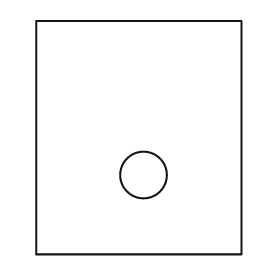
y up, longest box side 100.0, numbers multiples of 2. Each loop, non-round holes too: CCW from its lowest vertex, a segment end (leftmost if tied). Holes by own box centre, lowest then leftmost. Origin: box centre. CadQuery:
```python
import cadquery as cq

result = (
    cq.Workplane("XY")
    .moveTo(-44.0, -50.0)
    .lineTo(44.0, -50.0)
    .lineTo(44.0, 50.0)
    .lineTo(-44.0, 50.0)
    .close()
    .moveTo(2.0, -16.0)
    .circle(10.0)
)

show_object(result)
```